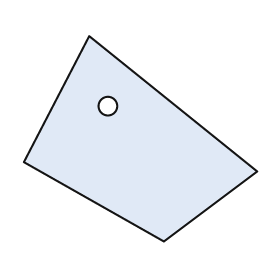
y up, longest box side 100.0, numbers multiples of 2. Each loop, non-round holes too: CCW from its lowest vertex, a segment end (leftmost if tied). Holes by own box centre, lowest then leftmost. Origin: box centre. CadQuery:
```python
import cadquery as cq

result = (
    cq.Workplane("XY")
    .moveTo(10.0, -44.0)
    .lineTo(50.0, -14.0)
    .lineTo(-22.0, 44.0)
    .lineTo(-50.0, -10.0)
    .close()
    .moveTo(-14.0, 14.0)
    .circle(4.0)
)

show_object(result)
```